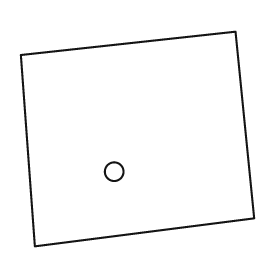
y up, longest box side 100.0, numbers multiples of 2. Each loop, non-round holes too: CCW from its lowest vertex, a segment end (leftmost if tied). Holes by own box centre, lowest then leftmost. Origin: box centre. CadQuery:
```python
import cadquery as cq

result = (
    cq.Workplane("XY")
    .moveTo(-44.0, -46.0)
    .lineTo(50.0, -34.0)
    .lineTo(42.0, 46.0)
    .lineTo(-50.0, 36.0)
    .close()
    .moveTo(-10.0, -14.0)
    .circle(4.0)
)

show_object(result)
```